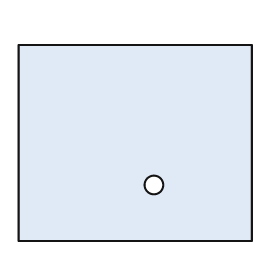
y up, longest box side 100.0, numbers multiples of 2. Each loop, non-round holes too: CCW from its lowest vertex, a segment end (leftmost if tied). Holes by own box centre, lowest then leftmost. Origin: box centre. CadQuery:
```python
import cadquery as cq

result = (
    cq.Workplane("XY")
    .moveTo(-50.0, -42.0)
    .lineTo(50.0, -42.0)
    .lineTo(50.0, 42.0)
    .lineTo(-50.0, 42.0)
    .close()
    .moveTo(8.0, -18.0)
    .circle(4.0)
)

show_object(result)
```